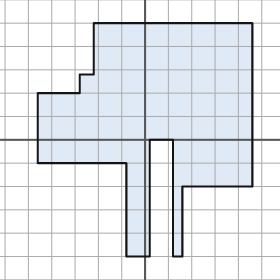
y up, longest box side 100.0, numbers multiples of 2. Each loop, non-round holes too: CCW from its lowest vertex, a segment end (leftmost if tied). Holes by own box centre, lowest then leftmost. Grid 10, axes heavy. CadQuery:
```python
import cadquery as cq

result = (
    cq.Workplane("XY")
    .moveTo(-8.0, -50.0)
    .lineTo(2.0, -50.0)
    .lineTo(2.0, 0.0)
    .lineTo(12.0, 0.0)
    .lineTo(12.0, -50.0)
    .lineTo(16.0, -50.0)
    .lineTo(16.0, -20.0)
    .lineTo(46.0, -20.0)
    .lineTo(46.0, 50.0)
    .lineTo(-22.0, 50.0)
    .lineTo(-22.0, 28.0)
    .lineTo(-28.0, 28.0)
    .lineTo(-28.0, 20.0)
    .lineTo(-46.0, 20.0)
    .lineTo(-46.0, -10.0)
    .lineTo(-8.0, -10.0)
    .close()
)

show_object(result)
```